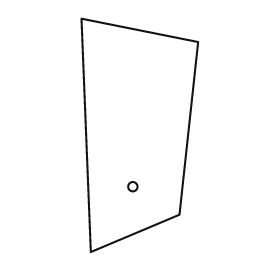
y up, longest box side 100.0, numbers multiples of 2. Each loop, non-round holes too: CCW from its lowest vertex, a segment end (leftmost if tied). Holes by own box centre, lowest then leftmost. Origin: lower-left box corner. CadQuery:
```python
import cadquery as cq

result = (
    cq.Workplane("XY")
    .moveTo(4.0, 0.0)
    .lineTo(42.0, 16.0)
    .lineTo(50.0, 90.0)
    .lineTo(0.0, 100.0)
    .close()
    .moveTo(22.0, 28.0)
    .circle(2.0)
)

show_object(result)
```